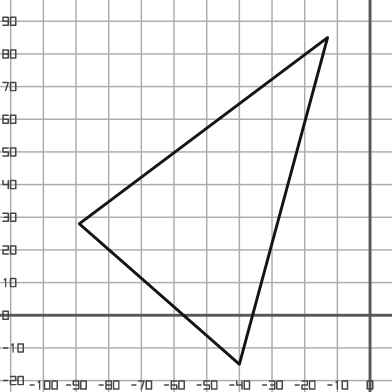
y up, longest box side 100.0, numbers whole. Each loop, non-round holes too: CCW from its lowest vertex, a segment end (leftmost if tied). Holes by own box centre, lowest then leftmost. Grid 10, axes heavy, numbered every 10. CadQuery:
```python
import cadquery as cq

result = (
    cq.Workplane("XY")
    .moveTo(-40.0, -15.0)
    .lineTo(-13.0, 85.0)
    .lineTo(-89.0, 28.0)
    .close()
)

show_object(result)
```